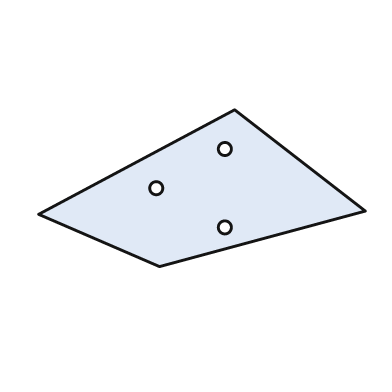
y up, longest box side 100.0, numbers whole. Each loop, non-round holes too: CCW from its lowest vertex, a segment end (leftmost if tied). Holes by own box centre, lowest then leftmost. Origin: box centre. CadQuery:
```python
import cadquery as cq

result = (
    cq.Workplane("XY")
    .moveTo(-13.0, -24.0)
    .lineTo(50.0, -7.0)
    .lineTo(10.0, 24.0)
    .lineTo(-50.0, -8.0)
    .close()
    .moveTo(7.0, -12.0)
    .circle(2.0)
    .moveTo(-14.0, 0.0)
    .circle(2.0)
    .moveTo(7.0, 12.0)
    .circle(2.0)
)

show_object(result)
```